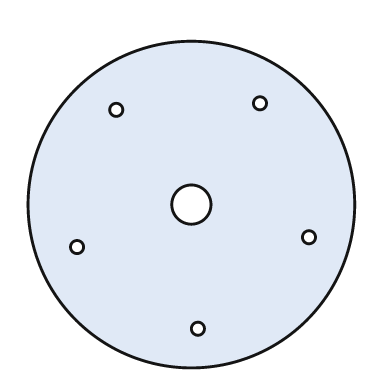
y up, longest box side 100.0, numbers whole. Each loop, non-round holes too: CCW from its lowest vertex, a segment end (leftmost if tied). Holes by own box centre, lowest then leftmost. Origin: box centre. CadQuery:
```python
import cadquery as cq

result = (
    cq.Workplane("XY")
    .moveTo(0.0, 0.0)
    .circle(50.0)
    .moveTo(2.0, -38.0)
    .circle(2.0)
    .moveTo(-35.0, -13.0)
    .circle(2.0)
    .moveTo(36.0, -10.0)
    .circle(2.0)
    .moveTo(0.0, 0.0)
    .circle(6.0)
    .moveTo(-23.0, 29.0)
    .circle(2.0)
    .moveTo(21.0, 31.0)
    .circle(2.0)
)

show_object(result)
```